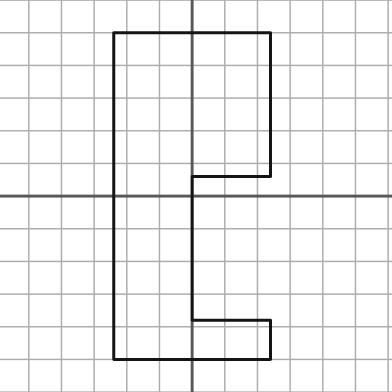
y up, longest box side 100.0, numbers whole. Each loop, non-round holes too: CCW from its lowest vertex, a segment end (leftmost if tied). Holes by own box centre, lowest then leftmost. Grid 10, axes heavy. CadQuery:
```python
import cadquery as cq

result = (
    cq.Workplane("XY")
    .moveTo(-24.0, -50.0)
    .lineTo(24.0, -50.0)
    .lineTo(24.0, -38.0)
    .lineTo(0.0, -38.0)
    .lineTo(0.0, 6.0)
    .lineTo(24.0, 6.0)
    .lineTo(24.0, 50.0)
    .lineTo(-24.0, 50.0)
    .close()
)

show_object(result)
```